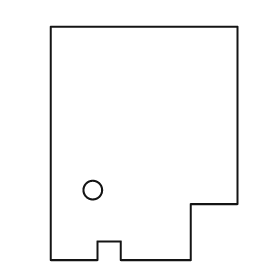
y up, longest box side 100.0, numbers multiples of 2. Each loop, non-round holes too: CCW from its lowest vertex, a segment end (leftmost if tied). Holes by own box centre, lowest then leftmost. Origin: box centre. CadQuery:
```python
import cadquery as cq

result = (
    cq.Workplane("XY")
    .moveTo(-40.0, -50.0)
    .lineTo(-20.0, -50.0)
    .lineTo(-20.0, -42.0)
    .lineTo(-10.0, -42.0)
    .lineTo(-10.0, -50.0)
    .lineTo(20.0, -50.0)
    .lineTo(20.0, -26.0)
    .lineTo(40.0, -26.0)
    .lineTo(40.0, 50.0)
    .lineTo(-40.0, 50.0)
    .close()
    .moveTo(-22.0, -20.0)
    .circle(4.0)
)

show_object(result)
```